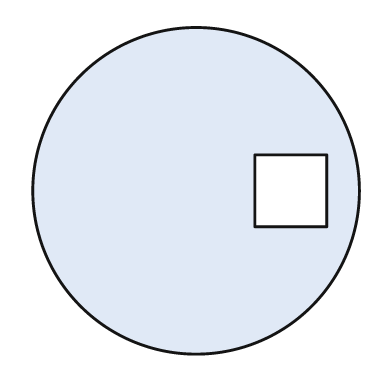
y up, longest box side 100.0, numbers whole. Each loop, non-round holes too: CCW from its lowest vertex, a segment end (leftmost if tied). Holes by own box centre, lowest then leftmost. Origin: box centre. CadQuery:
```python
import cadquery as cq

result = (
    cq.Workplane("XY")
    .moveTo(0.0, 0.0)
    .circle(50.0)
    .moveTo(18.0, -11.0)
    .lineTo(40.0, -11.0)
    .lineTo(40.0, 11.0)
    .lineTo(18.0, 11.0)
    .close()
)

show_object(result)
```